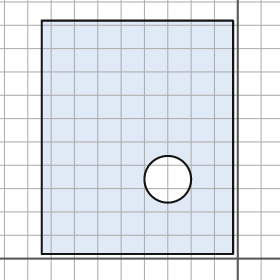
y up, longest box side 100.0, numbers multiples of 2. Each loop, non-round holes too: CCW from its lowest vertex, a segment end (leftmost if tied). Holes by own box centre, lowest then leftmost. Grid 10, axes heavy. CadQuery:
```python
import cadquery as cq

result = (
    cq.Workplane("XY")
    .moveTo(-84.0, 2.0)
    .lineTo(-2.0, 2.0)
    .lineTo(-2.0, 102.0)
    .lineTo(-84.0, 102.0)
    .close()
    .moveTo(-30.0, 34.0)
    .circle(10.0)
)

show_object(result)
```